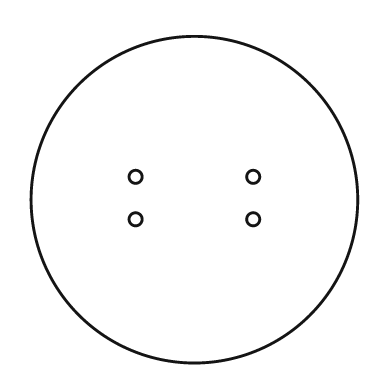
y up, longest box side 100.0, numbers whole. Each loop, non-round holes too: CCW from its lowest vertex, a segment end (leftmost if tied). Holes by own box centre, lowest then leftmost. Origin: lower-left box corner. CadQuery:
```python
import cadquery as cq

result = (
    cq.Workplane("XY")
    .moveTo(50.0, 50.0)
    .circle(50.0)
    .moveTo(32.0, 44.0)
    .circle(2.0)
    .moveTo(68.0, 44.0)
    .circle(2.0)
    .moveTo(32.0, 57.0)
    .circle(2.0)
    .moveTo(68.0, 57.0)
    .circle(2.0)
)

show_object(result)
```